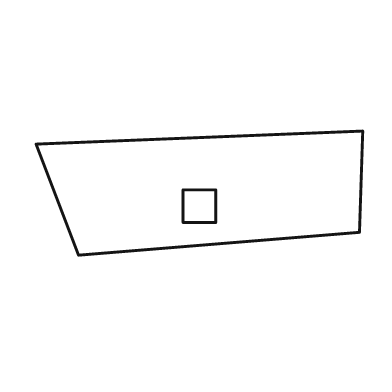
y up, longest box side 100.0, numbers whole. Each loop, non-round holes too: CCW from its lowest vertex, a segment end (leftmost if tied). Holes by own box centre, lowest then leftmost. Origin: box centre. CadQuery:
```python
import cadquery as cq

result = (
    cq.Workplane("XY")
    .moveTo(-37.0, -19.0)
    .lineTo(49.0, -12.0)
    .lineTo(50.0, 19.0)
    .lineTo(-50.0, 15.0)
    .close()
    .moveTo(-5.0, -9.0)
    .lineTo(5.0, -9.0)
    .lineTo(5.0, 1.0)
    .lineTo(-5.0, 1.0)
    .close()
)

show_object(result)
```